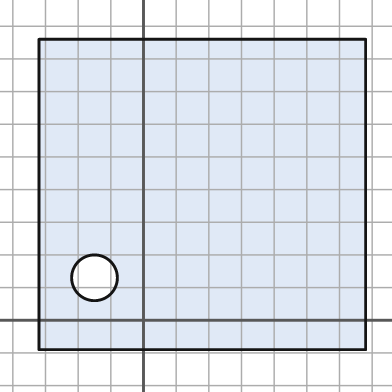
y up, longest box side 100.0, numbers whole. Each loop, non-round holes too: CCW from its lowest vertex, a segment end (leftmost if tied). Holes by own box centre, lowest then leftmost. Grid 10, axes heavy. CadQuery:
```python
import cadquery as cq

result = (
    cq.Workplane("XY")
    .moveTo(-32.0, -9.0)
    .lineTo(68.0, -9.0)
    .lineTo(68.0, 86.0)
    .lineTo(-32.0, 86.0)
    .close()
    .moveTo(-15.0, 13.0)
    .circle(7.0)
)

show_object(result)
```